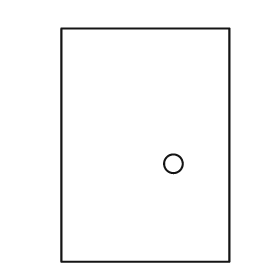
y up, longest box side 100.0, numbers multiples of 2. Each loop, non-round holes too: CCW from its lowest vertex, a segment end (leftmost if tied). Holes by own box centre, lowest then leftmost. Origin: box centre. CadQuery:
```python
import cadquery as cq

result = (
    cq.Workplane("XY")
    .moveTo(-36.0, -50.0)
    .lineTo(36.0, -50.0)
    .lineTo(36.0, 50.0)
    .lineTo(-36.0, 50.0)
    .close()
    .moveTo(12.0, -8.0)
    .circle(4.0)
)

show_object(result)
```